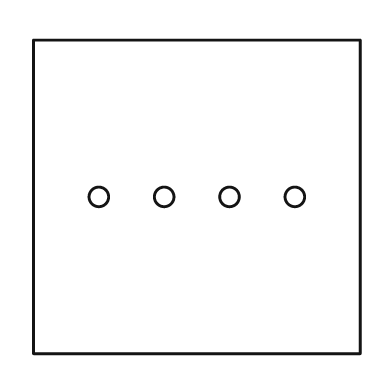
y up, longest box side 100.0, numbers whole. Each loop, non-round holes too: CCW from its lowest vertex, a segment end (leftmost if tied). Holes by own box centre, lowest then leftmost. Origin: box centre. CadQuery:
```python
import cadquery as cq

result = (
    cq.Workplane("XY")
    .moveTo(-50.0, -48.0)
    .lineTo(50.0, -48.0)
    .lineTo(50.0, 48.0)
    .lineTo(-50.0, 48.0)
    .close()
    .moveTo(-30.0, 0.0)
    .circle(3.0)
    .moveTo(-10.0, 0.0)
    .circle(3.0)
    .moveTo(10.0, 0.0)
    .circle(3.0)
    .moveTo(30.0, 0.0)
    .circle(3.0)
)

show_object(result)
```